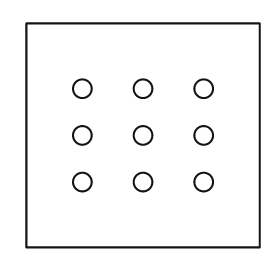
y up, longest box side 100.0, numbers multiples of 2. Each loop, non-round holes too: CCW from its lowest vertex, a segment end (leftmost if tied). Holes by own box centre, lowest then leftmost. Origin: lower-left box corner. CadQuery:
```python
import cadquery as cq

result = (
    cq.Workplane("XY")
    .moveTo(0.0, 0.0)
    .lineTo(100.0, 0.0)
    .lineTo(100.0, 96.0)
    .lineTo(0.0, 96.0)
    .close()
    .moveTo(24.0, 28.0)
    .circle(4.0)
    .moveTo(50.0, 28.0)
    .circle(4.0)
    .moveTo(76.0, 28.0)
    .circle(4.0)
    .moveTo(24.0, 48.0)
    .circle(4.0)
    .moveTo(50.0, 48.0)
    .circle(4.0)
    .moveTo(76.0, 48.0)
    .circle(4.0)
    .moveTo(24.0, 68.0)
    .circle(4.0)
    .moveTo(50.0, 68.0)
    .circle(4.0)
    .moveTo(76.0, 68.0)
    .circle(4.0)
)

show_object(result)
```